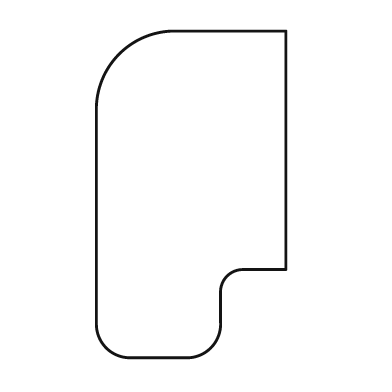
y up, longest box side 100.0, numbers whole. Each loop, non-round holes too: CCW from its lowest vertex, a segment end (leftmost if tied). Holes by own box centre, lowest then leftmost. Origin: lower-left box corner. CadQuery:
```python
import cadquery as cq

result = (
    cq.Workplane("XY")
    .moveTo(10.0, 0.0)
    .lineTo(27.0, 0.0)
    .threePointArc((35.0, 3.0), (38.0, 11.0))
    .lineTo(38.0, 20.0)
    .threePointArc((40.0, 25.0), (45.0, 27.0))
    .lineTo(58.0, 27.0)
    .lineTo(58.0, 100.0)
    .lineTo(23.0, 100.0)
    .threePointArc((7.0, 93.0), (0.0, 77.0))
    .lineTo(0.0, 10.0)
    .threePointArc((3.0, 3.0), (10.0, 0.0))
    .close()
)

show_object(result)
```